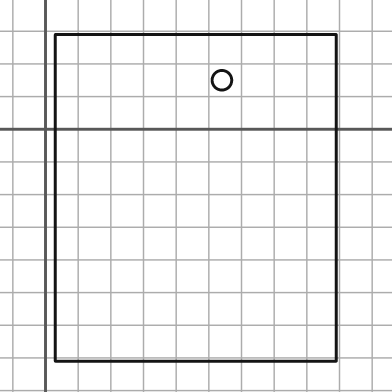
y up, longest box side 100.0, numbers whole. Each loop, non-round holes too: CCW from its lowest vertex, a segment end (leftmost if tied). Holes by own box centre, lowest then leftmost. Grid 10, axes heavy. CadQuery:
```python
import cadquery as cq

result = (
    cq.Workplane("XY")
    .moveTo(3.0, -71.0)
    .lineTo(89.0, -71.0)
    .lineTo(89.0, 29.0)
    .lineTo(3.0, 29.0)
    .close()
    .moveTo(54.0, 15.0)
    .circle(3.0)
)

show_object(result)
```